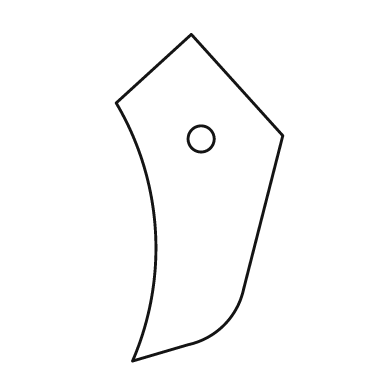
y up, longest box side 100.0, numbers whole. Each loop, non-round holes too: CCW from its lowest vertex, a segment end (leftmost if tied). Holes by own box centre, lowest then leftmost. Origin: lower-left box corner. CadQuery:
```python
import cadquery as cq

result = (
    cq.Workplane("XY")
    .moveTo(5.0, 0.0)
    .lineTo(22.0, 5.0)
    .threePointArc((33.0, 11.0), (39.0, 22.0))
    .lineTo(51.0, 69.0)
    .lineTo(23.0, 100.0)
    .lineTo(0.0, 79.0)
    .threePointArc((12.0, 40.0), (5.0, 0.0))
    .close()
    .moveTo(26.0, 68.0)
    .circle(4.0)
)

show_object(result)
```